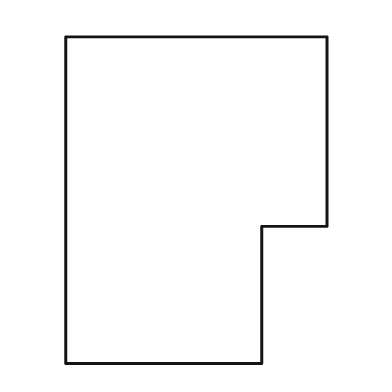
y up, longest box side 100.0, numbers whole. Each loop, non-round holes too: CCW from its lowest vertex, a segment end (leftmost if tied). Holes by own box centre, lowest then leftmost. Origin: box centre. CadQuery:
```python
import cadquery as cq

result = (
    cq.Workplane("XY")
    .moveTo(-40.0, -50.0)
    .lineTo(20.0, -50.0)
    .lineTo(20.0, -8.0)
    .lineTo(40.0, -8.0)
    .lineTo(40.0, 50.0)
    .lineTo(-40.0, 50.0)
    .close()
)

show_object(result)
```